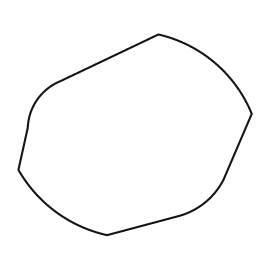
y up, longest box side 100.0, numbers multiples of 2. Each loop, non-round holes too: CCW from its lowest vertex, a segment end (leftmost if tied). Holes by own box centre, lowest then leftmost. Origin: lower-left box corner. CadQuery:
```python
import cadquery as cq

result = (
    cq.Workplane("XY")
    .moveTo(38.0, 0.0)
    .lineTo(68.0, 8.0)
    .threePointArc((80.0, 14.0), (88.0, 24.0))
    .lineTo(100.0, 52.0)
    .threePointArc((84.0, 74.0), (60.0, 86.0))
    .lineTo(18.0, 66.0)
    .threePointArc((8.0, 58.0), (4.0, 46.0))
    .lineTo(0.0, 28.0)
    .threePointArc((16.0, 10.0), (38.0, 0.0))
    .close()
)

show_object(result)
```